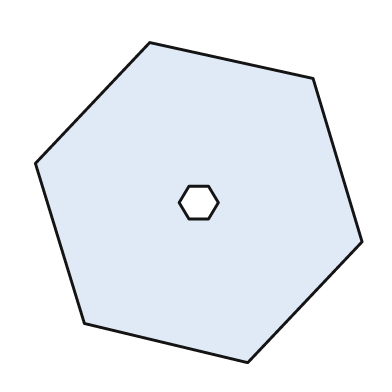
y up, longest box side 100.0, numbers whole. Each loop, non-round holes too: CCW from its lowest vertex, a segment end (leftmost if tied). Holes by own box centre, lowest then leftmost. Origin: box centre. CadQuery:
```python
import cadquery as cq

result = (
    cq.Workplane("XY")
    .moveTo(15.0, -49.0)
    .lineTo(50.0, -12.0)
    .lineTo(35.0, 38.0)
    .lineTo(-15.0, 49.0)
    .lineTo(-50.0, 12.0)
    .lineTo(-35.0, -37.0)
    .close()
    .moveTo(-3.0, -5.0)
    .lineTo(3.0, -5.0)
    .lineTo(6.0, 0.0)
    .lineTo(3.0, 5.0)
    .lineTo(-3.0, 5.0)
    .lineTo(-6.0, 0.0)
    .close()
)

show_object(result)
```